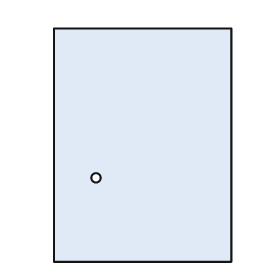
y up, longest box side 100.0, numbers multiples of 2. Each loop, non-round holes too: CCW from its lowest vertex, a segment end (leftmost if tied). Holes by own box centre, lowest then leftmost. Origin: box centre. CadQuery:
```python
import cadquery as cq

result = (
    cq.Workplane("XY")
    .moveTo(-38.0, -50.0)
    .lineTo(38.0, -50.0)
    .lineTo(38.0, 50.0)
    .lineTo(-38.0, 50.0)
    .close()
    .moveTo(-20.0, -14.0)
    .circle(2.0)
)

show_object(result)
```